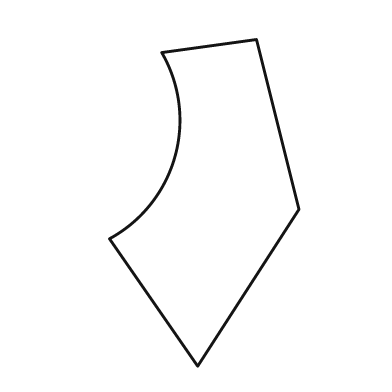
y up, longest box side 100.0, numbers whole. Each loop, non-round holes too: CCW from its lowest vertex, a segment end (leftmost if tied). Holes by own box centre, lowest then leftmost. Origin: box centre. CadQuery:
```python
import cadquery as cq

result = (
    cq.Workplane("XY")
    .moveTo(-2.0, -50.0)
    .lineTo(29.0, -2.0)
    .lineTo(16.0, 50.0)
    .lineTo(-13.0, 46.0)
    .threePointArc((-9.0, 14.0), (-29.0, -11.0))
    .close()
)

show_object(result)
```